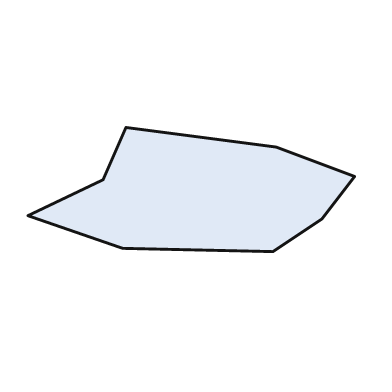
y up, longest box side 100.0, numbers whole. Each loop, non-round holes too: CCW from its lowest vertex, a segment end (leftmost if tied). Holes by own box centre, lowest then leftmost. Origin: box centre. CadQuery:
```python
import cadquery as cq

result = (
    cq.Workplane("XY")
    .moveTo(25.0, -19.0)
    .lineTo(40.0, -9.0)
    .lineTo(50.0, 4.0)
    .lineTo(26.0, 13.0)
    .lineTo(-20.0, 19.0)
    .lineTo(-27.0, 3.0)
    .lineTo(-50.0, -8.0)
    .lineTo(-21.0, -18.0)
    .close()
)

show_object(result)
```